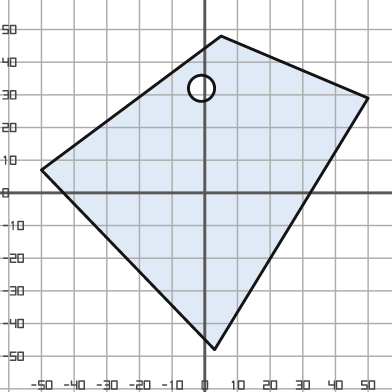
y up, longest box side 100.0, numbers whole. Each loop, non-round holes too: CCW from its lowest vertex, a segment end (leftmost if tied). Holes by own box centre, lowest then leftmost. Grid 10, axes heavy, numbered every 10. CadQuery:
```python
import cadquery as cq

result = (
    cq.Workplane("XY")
    .moveTo(3.0, -48.0)
    .lineTo(50.0, 29.0)
    .lineTo(5.0, 48.0)
    .lineTo(-50.0, 7.0)
    .close()
    .moveTo(-1.0, 32.0)
    .circle(4.0)
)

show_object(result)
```